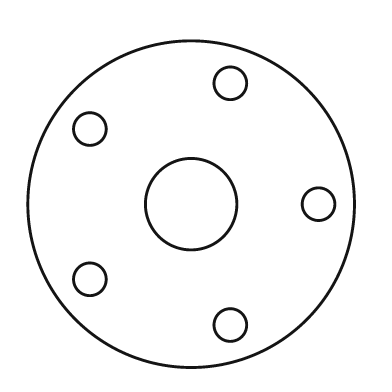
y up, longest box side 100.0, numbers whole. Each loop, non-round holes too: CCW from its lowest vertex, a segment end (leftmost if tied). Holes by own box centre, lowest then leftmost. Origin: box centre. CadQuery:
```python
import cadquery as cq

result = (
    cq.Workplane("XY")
    .moveTo(0.0, 0.0)
    .circle(50.0)
    .moveTo(12.0, -37.0)
    .circle(5.0)
    .moveTo(-31.0, -23.0)
    .circle(5.0)
    .moveTo(0.0, 0.0)
    .circle(14.0)
    .moveTo(39.0, 0.0)
    .circle(5.0)
    .moveTo(-31.0, 23.0)
    .circle(5.0)
    .moveTo(12.0, 37.0)
    .circle(5.0)
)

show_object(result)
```